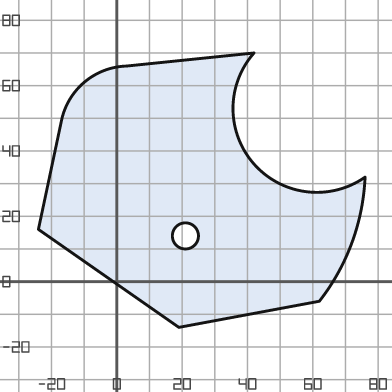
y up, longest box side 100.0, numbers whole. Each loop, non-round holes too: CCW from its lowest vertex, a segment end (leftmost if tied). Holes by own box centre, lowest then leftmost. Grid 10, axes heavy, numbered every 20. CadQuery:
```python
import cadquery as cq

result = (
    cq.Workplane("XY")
    .moveTo(19.0, -14.0)
    .lineTo(62.0, -6.0)
    .threePointArc((72.0, 12.0), (76.0, 32.0))
    .threePointArc((42.0, 36.0), (42.0, 70.0))
    .lineTo(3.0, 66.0)
    .threePointArc((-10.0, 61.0), (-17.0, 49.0))
    .lineTo(-24.0, 16.0)
    .close()
    .moveTo(21.0, 14.0)
    .circle(4.0)
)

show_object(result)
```